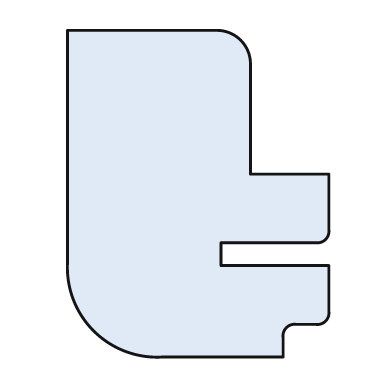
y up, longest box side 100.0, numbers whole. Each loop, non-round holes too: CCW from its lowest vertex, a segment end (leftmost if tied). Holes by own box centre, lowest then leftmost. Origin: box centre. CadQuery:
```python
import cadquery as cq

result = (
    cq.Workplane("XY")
    .moveTo(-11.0, -50.0)
    .lineTo(26.0, -50.0)
    .lineTo(26.0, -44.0)
    .threePointArc((27.0, -41.0), (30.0, -40.0))
    .lineTo(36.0, -40.0)
    .threePointArc((39.0, -39.0), (40.0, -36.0))
    .lineTo(40.0, -22.0)
    .lineTo(7.0, -22.0)
    .lineTo(7.0, -15.0)
    .lineTo(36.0, -15.0)
    .threePointArc((39.0, -14.0), (40.0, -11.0))
    .lineTo(40.0, 6.0)
    .lineTo(16.0, 6.0)
    .lineTo(16.0, 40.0)
    .threePointArc((13.0, 47.0), (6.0, 50.0))
    .lineTo(-40.0, 50.0)
    .lineTo(-40.0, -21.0)
    .threePointArc((-32.0, -42.0), (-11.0, -50.0))
    .close()
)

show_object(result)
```